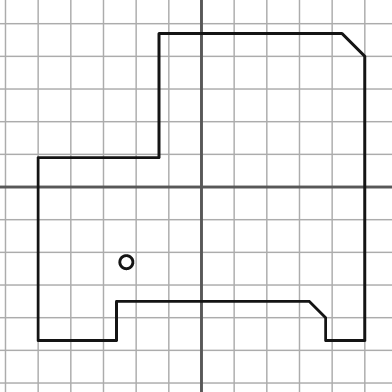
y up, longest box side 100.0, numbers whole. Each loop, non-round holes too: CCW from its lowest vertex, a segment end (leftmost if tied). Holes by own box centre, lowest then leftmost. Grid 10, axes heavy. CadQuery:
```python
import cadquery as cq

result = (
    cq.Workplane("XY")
    .moveTo(-50.0, -47.0)
    .lineTo(-26.0, -47.0)
    .lineTo(-26.0, -35.0)
    .lineTo(33.0, -35.0)
    .lineTo(38.0, -40.0)
    .lineTo(38.0, -47.0)
    .lineTo(50.0, -47.0)
    .lineTo(50.0, 40.0)
    .lineTo(43.0, 47.0)
    .lineTo(-13.0, 47.0)
    .lineTo(-13.0, 9.0)
    .lineTo(-50.0, 9.0)
    .close()
    .moveTo(-23.0, -23.0)
    .circle(2.0)
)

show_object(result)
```